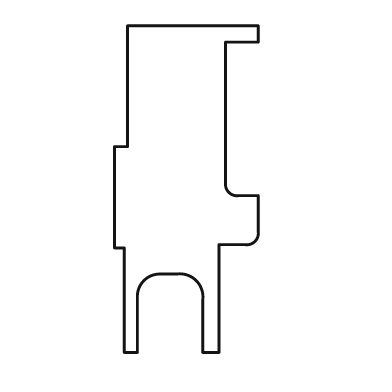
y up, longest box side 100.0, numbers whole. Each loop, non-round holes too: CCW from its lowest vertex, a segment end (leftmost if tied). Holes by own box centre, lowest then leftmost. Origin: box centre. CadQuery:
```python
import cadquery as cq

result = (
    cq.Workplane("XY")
    .moveTo(-19.0, -50.0)
    .lineTo(-15.0, -50.0)
    .lineTo(-15.0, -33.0)
    .threePointArc((-13.0, -28.0), (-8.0, -26.0))
    .lineTo(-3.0, -26.0)
    .threePointArc((3.0, -28.0), (5.0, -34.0))
    .lineTo(5.0, -50.0)
    .lineTo(10.0, -50.0)
    .lineTo(10.0, -17.0)
    .lineTo(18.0, -17.0)
    .threePointArc((21.0, -16.0), (22.0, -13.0))
    .lineTo(22.0, -2.0)
    .lineTo(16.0, -2.0)
    .threePointArc((13.0, -1.0), (12.0, 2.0))
    .lineTo(12.0, 45.0)
    .lineTo(22.0, 45.0)
    .lineTo(22.0, 50.0)
    .lineTo(-18.0, 50.0)
    .lineTo(-18.0, 13.0)
    .lineTo(-22.0, 13.0)
    .lineTo(-22.0, -18.0)
    .lineTo(-19.0, -18.0)
    .close()
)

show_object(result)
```